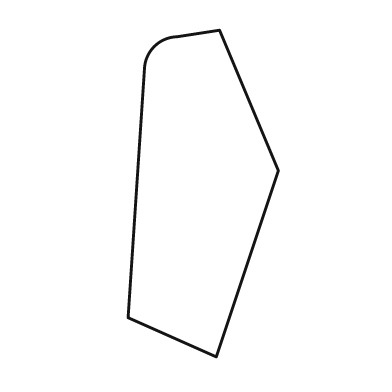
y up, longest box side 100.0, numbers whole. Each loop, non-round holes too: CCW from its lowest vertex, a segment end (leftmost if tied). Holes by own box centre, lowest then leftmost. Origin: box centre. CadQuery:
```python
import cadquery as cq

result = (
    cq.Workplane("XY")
    .moveTo(4.0, -50.0)
    .lineTo(23.0, 7.0)
    .lineTo(5.0, 50.0)
    .lineTo(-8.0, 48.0)
    .threePointArc((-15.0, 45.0), (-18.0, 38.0))
    .lineTo(-23.0, -38.0)
    .close()
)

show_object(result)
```